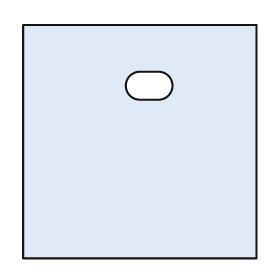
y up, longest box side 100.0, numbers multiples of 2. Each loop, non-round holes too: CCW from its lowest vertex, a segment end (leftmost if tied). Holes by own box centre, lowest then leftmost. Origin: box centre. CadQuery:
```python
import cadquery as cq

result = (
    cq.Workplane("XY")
    .moveTo(-50.0, -50.0)
    .lineTo(50.0, -50.0)
    .lineTo(50.0, 50.0)
    .lineTo(-50.0, 50.0)
    .close()
    .moveTo(0.0, 18.0)
    .lineTo(8.0, 18.0)
    .threePointArc((14.0, 24.0), (8.0, 30.0))
    .lineTo(0.0, 30.0)
    .threePointArc((-6.0, 24.0), (0.0, 18.0))
    .close()
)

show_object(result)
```